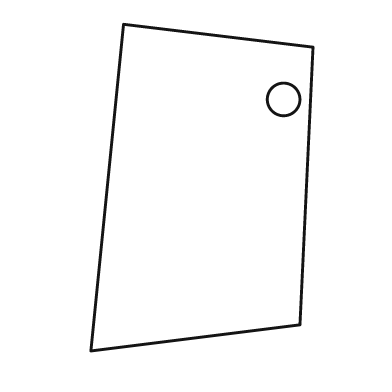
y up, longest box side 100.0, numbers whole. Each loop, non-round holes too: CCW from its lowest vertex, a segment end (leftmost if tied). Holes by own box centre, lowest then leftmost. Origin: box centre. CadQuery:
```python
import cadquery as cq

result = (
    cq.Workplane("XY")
    .moveTo(-34.0, -50.0)
    .lineTo(30.0, -42.0)
    .lineTo(34.0, 43.0)
    .lineTo(-24.0, 50.0)
    .close()
    .moveTo(25.0, 27.0)
    .circle(5.0)
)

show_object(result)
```